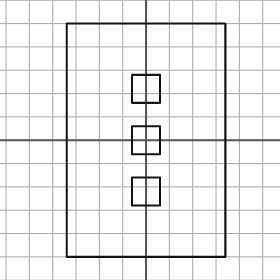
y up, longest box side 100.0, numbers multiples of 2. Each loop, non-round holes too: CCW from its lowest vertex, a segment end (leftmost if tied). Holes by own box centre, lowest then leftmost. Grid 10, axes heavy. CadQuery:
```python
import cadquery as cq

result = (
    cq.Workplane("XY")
    .moveTo(-34.0, -50.0)
    .lineTo(34.0, -50.0)
    .lineTo(34.0, 50.0)
    .lineTo(-34.0, 50.0)
    .close()
    .moveTo(-6.0, -28.0)
    .lineTo(6.0, -28.0)
    .lineTo(6.0, -16.0)
    .lineTo(-6.0, -16.0)
    .close()
    .moveTo(-6.0, -6.0)
    .lineTo(6.0, -6.0)
    .lineTo(6.0, 6.0)
    .lineTo(-6.0, 6.0)
    .close()
    .moveTo(-6.0, 16.0)
    .lineTo(6.0, 16.0)
    .lineTo(6.0, 28.0)
    .lineTo(-6.0, 28.0)
    .close()
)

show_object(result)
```